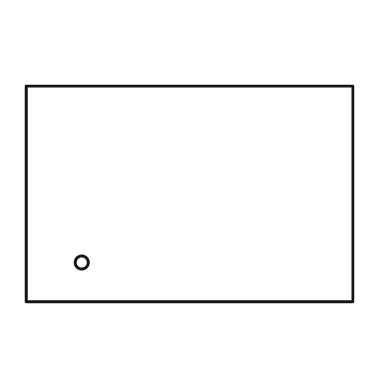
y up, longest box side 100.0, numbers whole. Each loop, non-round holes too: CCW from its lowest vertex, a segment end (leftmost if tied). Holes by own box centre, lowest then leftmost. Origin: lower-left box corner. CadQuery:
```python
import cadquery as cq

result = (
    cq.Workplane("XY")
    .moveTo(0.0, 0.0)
    .lineTo(100.0, 0.0)
    .lineTo(100.0, 66.0)
    .lineTo(0.0, 66.0)
    .close()
    .moveTo(17.0, 12.0)
    .circle(2.0)
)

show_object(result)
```